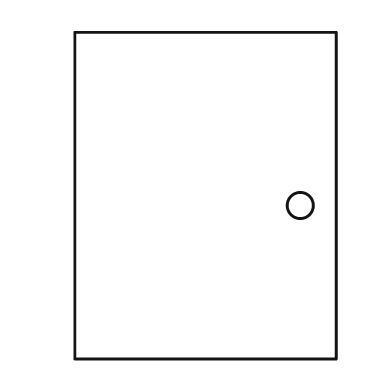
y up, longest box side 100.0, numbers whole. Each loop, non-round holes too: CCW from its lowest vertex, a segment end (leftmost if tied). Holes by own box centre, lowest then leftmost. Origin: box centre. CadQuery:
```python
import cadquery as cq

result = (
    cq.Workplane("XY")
    .moveTo(-40.0, -50.0)
    .lineTo(40.0, -50.0)
    .lineTo(40.0, 50.0)
    .lineTo(-40.0, 50.0)
    .close()
    .moveTo(29.0, -3.0)
    .circle(4.0)
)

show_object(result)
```